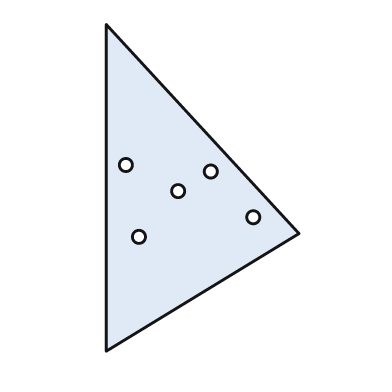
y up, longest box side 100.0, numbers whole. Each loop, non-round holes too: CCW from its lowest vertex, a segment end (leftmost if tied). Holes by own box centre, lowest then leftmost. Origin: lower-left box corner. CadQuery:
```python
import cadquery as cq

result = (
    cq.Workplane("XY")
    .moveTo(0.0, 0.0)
    .lineTo(59.0, 36.0)
    .lineTo(0.0, 100.0)
    .close()
    .moveTo(10.0, 35.0)
    .circle(2.0)
    .moveTo(45.0, 41.0)
    .circle(2.0)
    .moveTo(22.0, 49.0)
    .circle(2.0)
    .moveTo(32.0, 55.0)
    .circle(2.0)
    .moveTo(6.0, 57.0)
    .circle(2.0)
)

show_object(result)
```